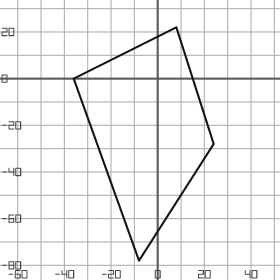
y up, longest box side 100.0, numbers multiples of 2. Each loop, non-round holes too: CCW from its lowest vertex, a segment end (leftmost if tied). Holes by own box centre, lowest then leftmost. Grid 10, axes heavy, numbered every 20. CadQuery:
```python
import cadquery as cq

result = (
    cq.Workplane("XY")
    .moveTo(-8.0, -78.0)
    .lineTo(24.0, -28.0)
    .lineTo(8.0, 22.0)
    .lineTo(-36.0, 0.0)
    .close()
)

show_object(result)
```